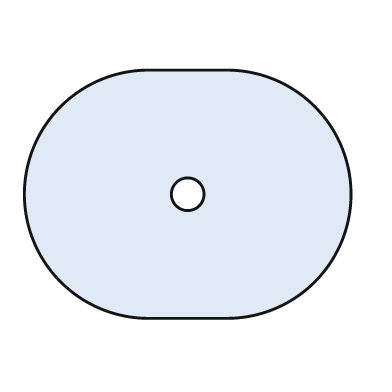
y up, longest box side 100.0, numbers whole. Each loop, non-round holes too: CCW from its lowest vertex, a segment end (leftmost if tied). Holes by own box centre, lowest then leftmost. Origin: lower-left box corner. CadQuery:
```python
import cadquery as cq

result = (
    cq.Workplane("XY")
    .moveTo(38.0, 0.0)
    .lineTo(62.0, 0.0)
    .threePointArc((100.0, 38.0), (62.0, 76.0))
    .lineTo(38.0, 76.0)
    .threePointArc((0.0, 38.0), (38.0, 0.0))
    .close()
    .moveTo(50.0, 38.0)
    .circle(5.0)
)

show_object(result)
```